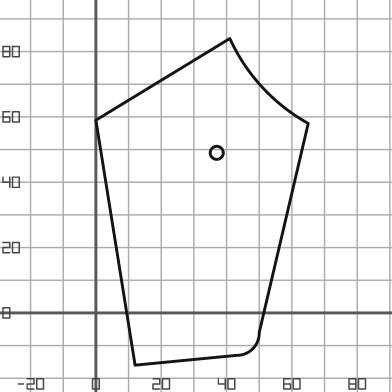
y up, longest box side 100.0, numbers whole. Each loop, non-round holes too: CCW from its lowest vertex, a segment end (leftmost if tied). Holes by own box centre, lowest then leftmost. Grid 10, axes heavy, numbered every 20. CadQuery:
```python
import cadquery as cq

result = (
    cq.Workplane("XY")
    .moveTo(12.0, -16.0)
    .lineTo(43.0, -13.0)
    .threePointArc((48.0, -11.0), (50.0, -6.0))
    .lineTo(65.0, 58.0)
    .threePointArc((51.0, 69.0), (41.0, 84.0))
    .lineTo(0.0, 59.0)
    .close()
    .moveTo(37.0, 49.0)
    .circle(2.0)
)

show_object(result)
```